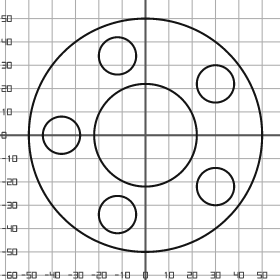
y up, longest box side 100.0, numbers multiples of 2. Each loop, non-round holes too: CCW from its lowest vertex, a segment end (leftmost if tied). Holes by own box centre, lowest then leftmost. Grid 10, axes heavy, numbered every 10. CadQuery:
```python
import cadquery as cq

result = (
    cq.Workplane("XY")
    .moveTo(0.0, 0.0)
    .circle(50.0)
    .moveTo(-12.0, -34.0)
    .circle(8.0)
    .moveTo(30.0, -22.0)
    .circle(8.0)
    .moveTo(-36.0, 0.0)
    .circle(8.0)
    .moveTo(0.0, 0.0)
    .circle(22.0)
    .moveTo(30.0, 22.0)
    .circle(8.0)
    .moveTo(-12.0, 34.0)
    .circle(8.0)
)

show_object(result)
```